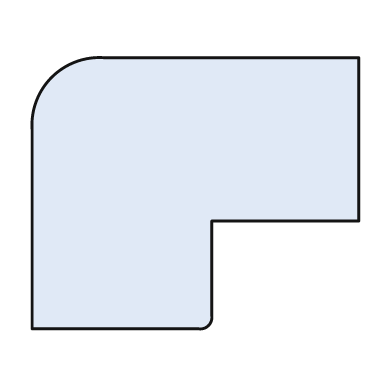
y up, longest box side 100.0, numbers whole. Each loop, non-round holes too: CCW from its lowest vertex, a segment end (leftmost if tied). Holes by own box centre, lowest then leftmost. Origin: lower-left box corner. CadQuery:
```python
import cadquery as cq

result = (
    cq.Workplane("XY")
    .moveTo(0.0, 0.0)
    .lineTo(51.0, 0.0)
    .threePointArc((54.0, 1.0), (55.0, 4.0))
    .lineTo(55.0, 33.0)
    .lineTo(100.0, 33.0)
    .lineTo(100.0, 83.0)
    .lineTo(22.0, 83.0)
    .threePointArc((6.0, 77.0), (0.0, 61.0))
    .close()
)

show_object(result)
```